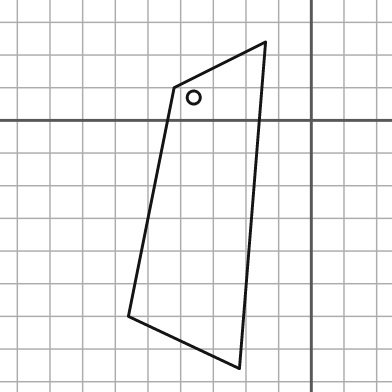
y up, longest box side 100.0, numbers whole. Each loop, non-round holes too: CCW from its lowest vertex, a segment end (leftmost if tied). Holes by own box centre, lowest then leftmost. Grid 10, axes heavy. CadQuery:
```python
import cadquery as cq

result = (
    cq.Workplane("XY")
    .moveTo(-22.0, -76.0)
    .lineTo(-14.0, 24.0)
    .lineTo(-42.0, 10.0)
    .lineTo(-56.0, -60.0)
    .close()
    .moveTo(-36.0, 7.0)
    .circle(2.0)
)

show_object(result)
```